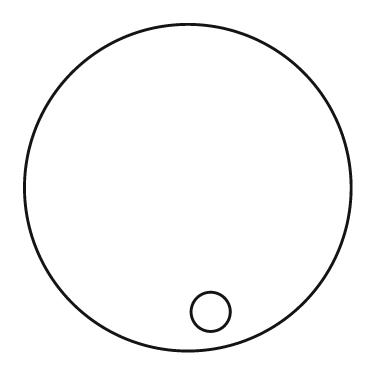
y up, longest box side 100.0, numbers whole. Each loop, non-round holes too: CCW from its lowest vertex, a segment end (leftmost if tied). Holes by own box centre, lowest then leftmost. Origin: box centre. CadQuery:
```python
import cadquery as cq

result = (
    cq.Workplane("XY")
    .moveTo(0.0, 0.0)
    .circle(50.0)
    .moveTo(7.0, -38.0)
    .circle(6.0)
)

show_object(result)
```